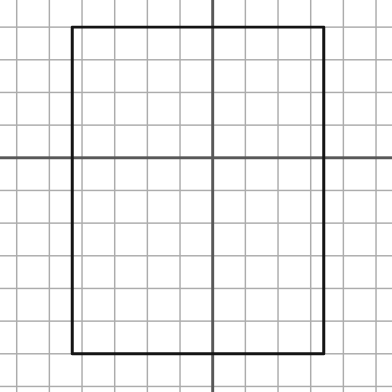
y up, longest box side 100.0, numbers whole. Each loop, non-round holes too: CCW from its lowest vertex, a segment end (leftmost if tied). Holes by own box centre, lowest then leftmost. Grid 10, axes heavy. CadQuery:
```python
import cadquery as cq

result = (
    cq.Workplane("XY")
    .moveTo(-43.0, -60.0)
    .lineTo(34.0, -60.0)
    .lineTo(34.0, 40.0)
    .lineTo(-43.0, 40.0)
    .close()
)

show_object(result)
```